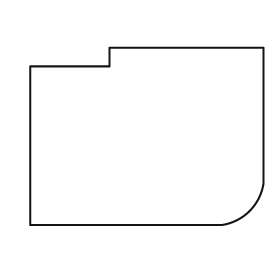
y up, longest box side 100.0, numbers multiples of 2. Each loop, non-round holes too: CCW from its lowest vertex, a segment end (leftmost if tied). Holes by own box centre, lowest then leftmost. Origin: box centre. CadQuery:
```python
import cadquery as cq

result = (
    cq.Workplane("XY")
    .moveTo(-50.0, -38.0)
    .lineTo(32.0, -38.0)
    .threePointArc((44.0, -32.0), (50.0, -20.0))
    .lineTo(50.0, 38.0)
    .lineTo(-16.0, 38.0)
    .lineTo(-16.0, 30.0)
    .lineTo(-50.0, 30.0)
    .close()
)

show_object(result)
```